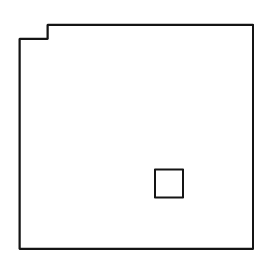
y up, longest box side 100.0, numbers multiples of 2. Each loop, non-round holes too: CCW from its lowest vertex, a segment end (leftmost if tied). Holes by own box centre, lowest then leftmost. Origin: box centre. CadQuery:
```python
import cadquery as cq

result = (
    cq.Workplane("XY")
    .moveTo(-50.0, -48.0)
    .lineTo(50.0, -48.0)
    .lineTo(50.0, 48.0)
    .lineTo(-38.0, 48.0)
    .lineTo(-38.0, 42.0)
    .lineTo(-50.0, 42.0)
    .close()
    .moveTo(8.0, -26.0)
    .lineTo(20.0, -26.0)
    .lineTo(20.0, -14.0)
    .lineTo(8.0, -14.0)
    .close()
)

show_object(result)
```